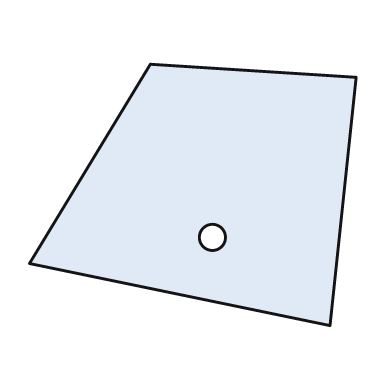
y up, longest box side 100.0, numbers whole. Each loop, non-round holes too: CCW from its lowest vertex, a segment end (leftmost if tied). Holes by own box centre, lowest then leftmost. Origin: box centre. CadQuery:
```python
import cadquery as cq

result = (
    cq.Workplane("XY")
    .moveTo(42.0, -40.0)
    .lineTo(50.0, 36.0)
    .lineTo(-13.0, 40.0)
    .lineTo(-50.0, -21.0)
    .close()
    .moveTo(6.0, -13.0)
    .circle(4.0)
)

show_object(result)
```